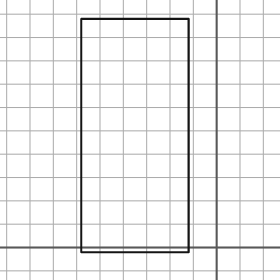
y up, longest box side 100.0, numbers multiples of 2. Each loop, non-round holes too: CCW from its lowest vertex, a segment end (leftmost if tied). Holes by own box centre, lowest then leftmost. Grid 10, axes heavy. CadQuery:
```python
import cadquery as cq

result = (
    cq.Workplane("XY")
    .moveTo(-58.0, -2.0)
    .lineTo(-12.0, -2.0)
    .lineTo(-12.0, 98.0)
    .lineTo(-58.0, 98.0)
    .close()
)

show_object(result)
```